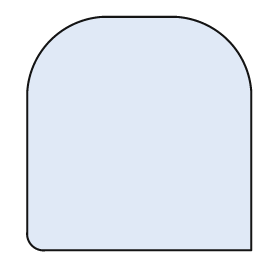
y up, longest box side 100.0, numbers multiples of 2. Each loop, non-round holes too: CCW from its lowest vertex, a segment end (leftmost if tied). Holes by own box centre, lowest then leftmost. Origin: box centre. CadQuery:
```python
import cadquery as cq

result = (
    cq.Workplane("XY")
    .moveTo(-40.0, -50.0)
    .lineTo(48.0, -50.0)
    .lineTo(48.0, 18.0)
    .threePointArc((38.0, 40.0), (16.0, 50.0))
    .lineTo(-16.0, 50.0)
    .threePointArc((-38.0, 40.0), (-48.0, 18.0))
    .lineTo(-48.0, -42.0)
    .threePointArc((-46.0, -48.0), (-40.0, -50.0))
    .close()
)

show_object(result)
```